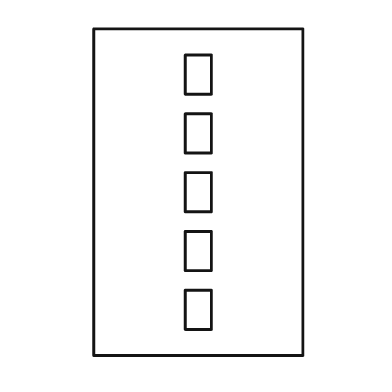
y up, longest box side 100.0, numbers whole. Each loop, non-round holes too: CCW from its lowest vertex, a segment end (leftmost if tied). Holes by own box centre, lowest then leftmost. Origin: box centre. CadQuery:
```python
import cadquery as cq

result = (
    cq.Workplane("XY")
    .moveTo(-32.0, -50.0)
    .lineTo(32.0, -50.0)
    .lineTo(32.0, 50.0)
    .lineTo(-32.0, 50.0)
    .close()
    .moveTo(-4.0, -42.0)
    .lineTo(4.0, -42.0)
    .lineTo(4.0, -30.0)
    .lineTo(-4.0, -30.0)
    .close()
    .moveTo(-4.0, -24.0)
    .lineTo(4.0, -24.0)
    .lineTo(4.0, -12.0)
    .lineTo(-4.0, -12.0)
    .close()
    .moveTo(-4.0, -6.0)
    .lineTo(4.0, -6.0)
    .lineTo(4.0, 6.0)
    .lineTo(-4.0, 6.0)
    .close()
    .moveTo(-4.0, 12.0)
    .lineTo(4.0, 12.0)
    .lineTo(4.0, 24.0)
    .lineTo(-4.0, 24.0)
    .close()
    .moveTo(-4.0, 30.0)
    .lineTo(4.0, 30.0)
    .lineTo(4.0, 42.0)
    .lineTo(-4.0, 42.0)
    .close()
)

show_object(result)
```